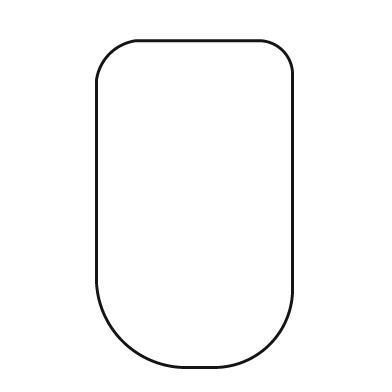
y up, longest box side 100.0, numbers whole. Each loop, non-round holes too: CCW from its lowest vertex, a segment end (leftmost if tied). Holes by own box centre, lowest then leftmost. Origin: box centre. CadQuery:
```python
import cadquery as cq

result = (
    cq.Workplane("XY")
    .moveTo(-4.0, -50.0)
    .lineTo(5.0, -50.0)
    .threePointArc((23.0, -43.0), (30.0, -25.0))
    .lineTo(30.0, 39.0)
    .threePointArc((27.0, 47.0), (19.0, 50.0))
    .lineTo(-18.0, 50.0)
    .threePointArc((-26.0, 46.0), (-30.0, 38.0))
    .lineTo(-30.0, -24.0)
    .threePointArc((-22.0, -42.0), (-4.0, -50.0))
    .close()
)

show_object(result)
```